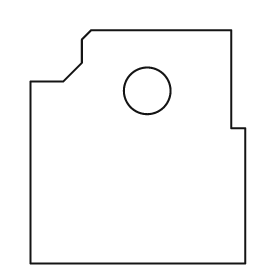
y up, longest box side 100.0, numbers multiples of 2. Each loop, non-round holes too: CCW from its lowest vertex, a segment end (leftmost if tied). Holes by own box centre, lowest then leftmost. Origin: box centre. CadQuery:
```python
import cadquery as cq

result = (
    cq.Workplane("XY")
    .moveTo(-46.0, -50.0)
    .lineTo(46.0, -50.0)
    .lineTo(46.0, 8.0)
    .lineTo(40.0, 8.0)
    .lineTo(40.0, 50.0)
    .lineTo(-20.0, 50.0)
    .lineTo(-24.0, 46.0)
    .lineTo(-24.0, 36.0)
    .lineTo(-32.0, 28.0)
    .lineTo(-46.0, 28.0)
    .close()
    .moveTo(4.0, 24.0)
    .circle(10.0)
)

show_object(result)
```